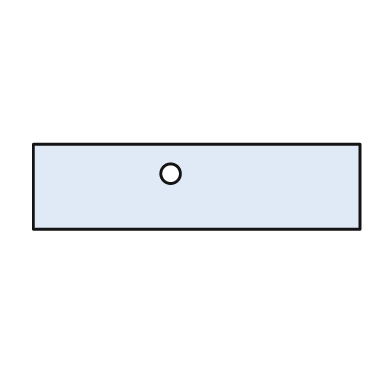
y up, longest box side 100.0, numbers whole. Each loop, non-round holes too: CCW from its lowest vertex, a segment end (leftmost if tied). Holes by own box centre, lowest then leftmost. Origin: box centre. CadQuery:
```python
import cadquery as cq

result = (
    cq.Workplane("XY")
    .moveTo(-50.0, -13.0)
    .lineTo(50.0, -13.0)
    .lineTo(50.0, 13.0)
    .lineTo(-50.0, 13.0)
    .close()
    .moveTo(-8.0, 4.0)
    .circle(3.0)
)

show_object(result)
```